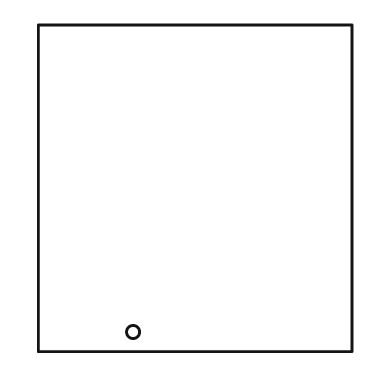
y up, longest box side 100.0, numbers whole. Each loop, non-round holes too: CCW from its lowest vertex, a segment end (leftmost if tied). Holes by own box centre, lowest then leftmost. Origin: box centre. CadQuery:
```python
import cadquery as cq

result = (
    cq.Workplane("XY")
    .moveTo(-48.0, -50.0)
    .lineTo(48.0, -50.0)
    .lineTo(48.0, 50.0)
    .lineTo(-48.0, 50.0)
    .close()
    .moveTo(-19.0, -44.0)
    .circle(2.0)
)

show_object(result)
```